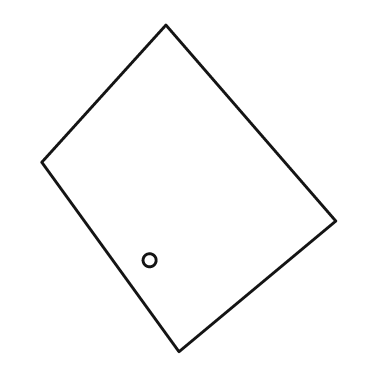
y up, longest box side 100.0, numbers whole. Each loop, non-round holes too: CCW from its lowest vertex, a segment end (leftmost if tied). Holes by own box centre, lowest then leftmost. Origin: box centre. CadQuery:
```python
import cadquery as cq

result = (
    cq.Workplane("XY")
    .moveTo(-3.0, -50.0)
    .lineTo(45.0, -10.0)
    .lineTo(-7.0, 50.0)
    .lineTo(-45.0, 8.0)
    .close()
    .moveTo(-12.0, -22.0)
    .circle(2.0)
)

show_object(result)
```